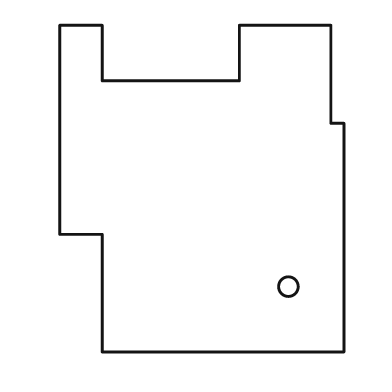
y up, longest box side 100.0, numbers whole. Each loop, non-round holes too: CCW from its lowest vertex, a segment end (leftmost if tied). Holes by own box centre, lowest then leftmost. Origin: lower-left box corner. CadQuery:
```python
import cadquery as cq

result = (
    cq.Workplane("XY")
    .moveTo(13.0, 0.0)
    .lineTo(87.0, 0.0)
    .lineTo(87.0, 70.0)
    .lineTo(83.0, 70.0)
    .lineTo(83.0, 100.0)
    .lineTo(55.0, 100.0)
    .lineTo(55.0, 83.0)
    .lineTo(13.0, 83.0)
    .lineTo(13.0, 100.0)
    .lineTo(0.0, 100.0)
    .lineTo(0.0, 36.0)
    .lineTo(13.0, 36.0)
    .close()
    .moveTo(70.0, 20.0)
    .circle(3.0)
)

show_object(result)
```